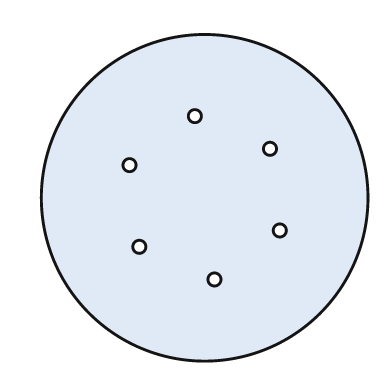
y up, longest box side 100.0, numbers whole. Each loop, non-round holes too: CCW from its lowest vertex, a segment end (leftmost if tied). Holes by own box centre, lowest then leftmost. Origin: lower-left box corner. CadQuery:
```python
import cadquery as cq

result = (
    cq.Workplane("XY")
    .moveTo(50.0, 50.0)
    .circle(50.0)
    .moveTo(53.0, 25.0)
    .circle(2.0)
    .moveTo(30.0, 35.0)
    .circle(2.0)
    .moveTo(73.0, 40.0)
    .circle(2.0)
    .moveTo(27.0, 60.0)
    .circle(2.0)
    .moveTo(70.0, 65.0)
    .circle(2.0)
    .moveTo(47.0, 75.0)
    .circle(2.0)
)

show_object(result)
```